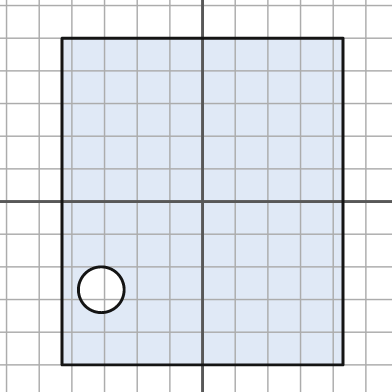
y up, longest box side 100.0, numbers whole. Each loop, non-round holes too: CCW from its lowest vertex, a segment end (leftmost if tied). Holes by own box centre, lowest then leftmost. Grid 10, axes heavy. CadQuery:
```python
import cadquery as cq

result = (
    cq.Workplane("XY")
    .moveTo(-43.0, -50.0)
    .lineTo(43.0, -50.0)
    .lineTo(43.0, 50.0)
    .lineTo(-43.0, 50.0)
    .close()
    .moveTo(-31.0, -27.0)
    .circle(7.0)
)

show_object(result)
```